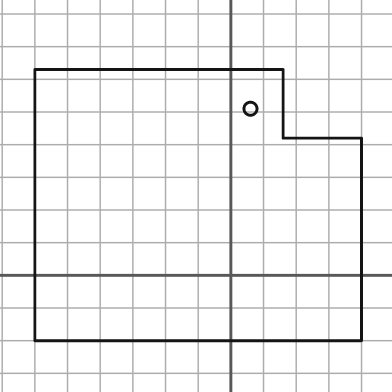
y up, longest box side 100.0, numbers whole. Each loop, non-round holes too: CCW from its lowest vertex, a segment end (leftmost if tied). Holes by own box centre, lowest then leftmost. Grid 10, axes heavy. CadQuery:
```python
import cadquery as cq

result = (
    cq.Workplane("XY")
    .moveTo(-60.0, -20.0)
    .lineTo(40.0, -20.0)
    .lineTo(40.0, 42.0)
    .lineTo(16.0, 42.0)
    .lineTo(16.0, 63.0)
    .lineTo(-60.0, 63.0)
    .close()
    .moveTo(6.0, 51.0)
    .circle(2.0)
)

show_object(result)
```